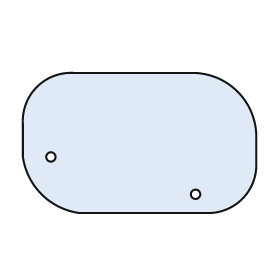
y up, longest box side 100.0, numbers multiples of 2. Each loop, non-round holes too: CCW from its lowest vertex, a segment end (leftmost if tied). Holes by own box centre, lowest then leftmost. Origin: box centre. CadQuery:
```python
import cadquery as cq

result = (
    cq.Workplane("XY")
    .moveTo(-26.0, -30.0)
    .lineTo(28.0, -30.0)
    .threePointArc((44.0, -24.0), (50.0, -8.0))
    .lineTo(50.0, 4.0)
    .threePointArc((42.0, 22.0), (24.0, 30.0))
    .lineTo(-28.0, 30.0)
    .threePointArc((-44.0, 24.0), (-50.0, 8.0))
    .lineTo(-50.0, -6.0)
    .threePointArc((-42.0, -22.0), (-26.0, -30.0))
    .close()
    .moveTo(24.0, -22.0)
    .circle(2.0)
    .moveTo(-38.0, -6.0)
    .circle(2.0)
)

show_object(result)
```